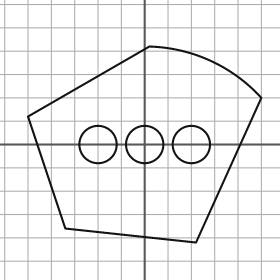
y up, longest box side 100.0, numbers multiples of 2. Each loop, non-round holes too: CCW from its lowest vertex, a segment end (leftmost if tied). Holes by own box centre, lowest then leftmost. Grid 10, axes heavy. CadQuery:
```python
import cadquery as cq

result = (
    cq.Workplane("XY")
    .moveTo(22.0, -42.0)
    .lineTo(50.0, 20.0)
    .threePointArc((28.0, 36.0), (2.0, 42.0))
    .lineTo(-50.0, 12.0)
    .lineTo(-34.0, -36.0)
    .close()
    .moveTo(-20.0, 0.0)
    .circle(8.0)
    .moveTo(0.0, 0.0)
    .circle(8.0)
    .moveTo(20.0, 0.0)
    .circle(8.0)
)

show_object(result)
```